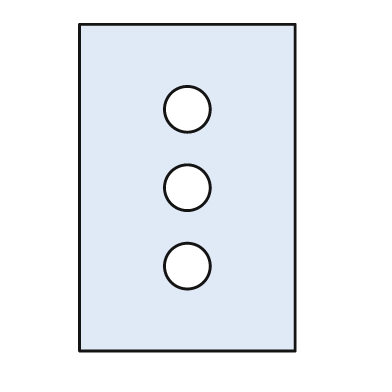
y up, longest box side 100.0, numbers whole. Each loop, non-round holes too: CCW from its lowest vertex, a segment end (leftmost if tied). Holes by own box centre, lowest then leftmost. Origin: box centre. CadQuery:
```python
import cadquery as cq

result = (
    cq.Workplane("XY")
    .moveTo(-33.0, -50.0)
    .lineTo(33.0, -50.0)
    .lineTo(33.0, 50.0)
    .lineTo(-33.0, 50.0)
    .close()
    .moveTo(0.0, -24.0)
    .circle(7.0)
    .moveTo(0.0, 0.0)
    .circle(7.0)
    .moveTo(0.0, 24.0)
    .circle(7.0)
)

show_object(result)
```